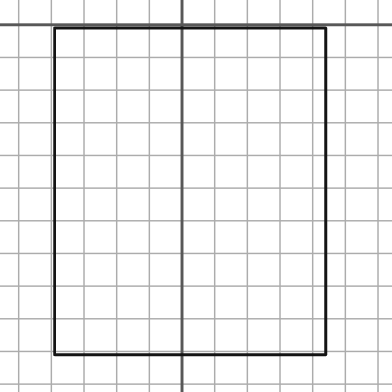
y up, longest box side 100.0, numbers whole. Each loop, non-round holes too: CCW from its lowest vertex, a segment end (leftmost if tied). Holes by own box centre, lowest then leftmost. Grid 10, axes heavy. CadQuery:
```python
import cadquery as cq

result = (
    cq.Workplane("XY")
    .moveTo(-39.0, -101.0)
    .lineTo(44.0, -101.0)
    .lineTo(44.0, -1.0)
    .lineTo(-39.0, -1.0)
    .close()
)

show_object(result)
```